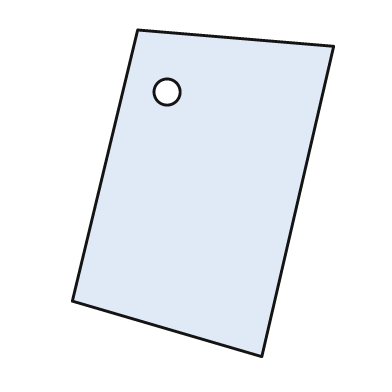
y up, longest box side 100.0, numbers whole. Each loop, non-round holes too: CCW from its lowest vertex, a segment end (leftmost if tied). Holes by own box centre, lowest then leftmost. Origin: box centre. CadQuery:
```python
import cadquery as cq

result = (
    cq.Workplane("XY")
    .moveTo(18.0, -50.0)
    .lineTo(40.0, 45.0)
    .lineTo(-20.0, 50.0)
    .lineTo(-40.0, -33.0)
    .close()
    .moveTo(-11.0, 31.0)
    .circle(4.0)
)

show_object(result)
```